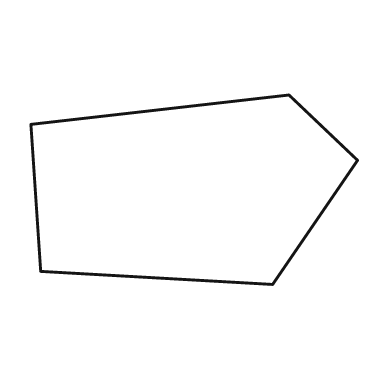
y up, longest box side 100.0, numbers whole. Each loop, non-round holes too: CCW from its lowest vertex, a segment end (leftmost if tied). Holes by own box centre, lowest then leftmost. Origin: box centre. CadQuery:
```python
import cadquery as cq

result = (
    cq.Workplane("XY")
    .moveTo(24.0, -29.0)
    .lineTo(50.0, 9.0)
    .lineTo(29.0, 29.0)
    .lineTo(-50.0, 20.0)
    .lineTo(-47.0, -25.0)
    .close()
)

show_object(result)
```